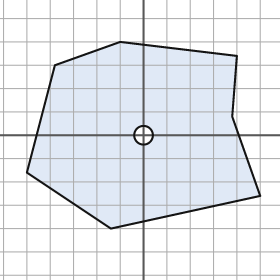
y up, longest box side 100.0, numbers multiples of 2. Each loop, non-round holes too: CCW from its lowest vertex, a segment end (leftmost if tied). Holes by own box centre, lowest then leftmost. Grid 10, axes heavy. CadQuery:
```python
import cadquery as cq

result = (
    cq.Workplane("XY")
    .moveTo(-14.0, -40.0)
    .lineTo(50.0, -26.0)
    .lineTo(38.0, 8.0)
    .lineTo(40.0, 34.0)
    .lineTo(-10.0, 40.0)
    .lineTo(-38.0, 30.0)
    .lineTo(-50.0, -16.0)
    .close()
    .moveTo(0.0, 0.0)
    .circle(4.0)
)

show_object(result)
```